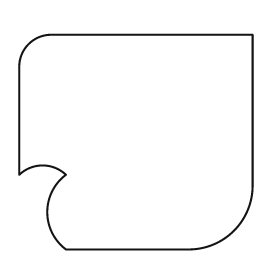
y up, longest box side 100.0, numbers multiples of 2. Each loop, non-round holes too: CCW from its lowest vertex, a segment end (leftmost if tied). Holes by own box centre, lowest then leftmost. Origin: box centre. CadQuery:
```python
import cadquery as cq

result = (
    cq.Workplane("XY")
    .moveTo(-30.0, -46.0)
    .lineTo(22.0, -46.0)
    .threePointArc((42.0, -38.0), (50.0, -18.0))
    .lineTo(50.0, 46.0)
    .lineTo(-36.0, 46.0)
    .threePointArc((-46.0, 42.0), (-50.0, 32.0))
    .lineTo(-50.0, -14.0)
    .threePointArc((-40.0, -10.0), (-30.0, -14.0))
    .threePointArc((-38.0, -30.0), (-30.0, -46.0))
    .close()
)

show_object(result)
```